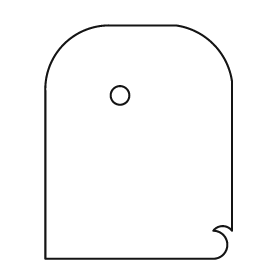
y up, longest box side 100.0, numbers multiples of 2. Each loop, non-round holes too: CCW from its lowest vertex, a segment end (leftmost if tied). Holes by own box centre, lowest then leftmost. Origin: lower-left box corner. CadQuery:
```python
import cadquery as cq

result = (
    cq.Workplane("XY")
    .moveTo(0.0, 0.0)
    .lineTo(72.0, 0.0)
    .threePointArc((78.0, 6.0), (72.0, 12.0))
    .threePointArc((76.0, 14.0), (80.0, 12.0))
    .lineTo(80.0, 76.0)
    .threePointArc((72.0, 92.0), (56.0, 100.0))
    .lineTo(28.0, 100.0)
    .threePointArc((8.0, 92.0), (0.0, 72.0))
    .close()
    .moveTo(32.0, 70.0)
    .circle(4.0)
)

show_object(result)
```